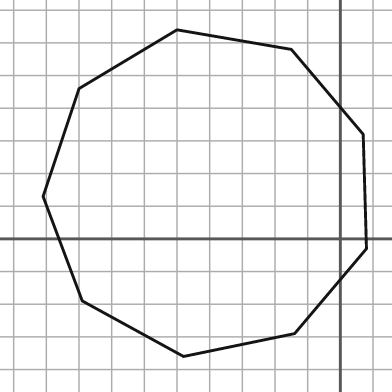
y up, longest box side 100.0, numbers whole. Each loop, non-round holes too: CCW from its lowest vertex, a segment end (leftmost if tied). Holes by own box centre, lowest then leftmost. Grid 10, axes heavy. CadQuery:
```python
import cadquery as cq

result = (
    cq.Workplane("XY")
    .moveTo(-48.0, -36.0)
    .lineTo(-14.0, -29.0)
    .lineTo(8.0, -3.0)
    .lineTo(7.0, 32.0)
    .lineTo(-15.0, 58.0)
    .lineTo(-50.0, 64.0)
    .lineTo(-80.0, 46.0)
    .lineTo(-91.0, 13.0)
    .lineTo(-79.0, -19.0)
    .close()
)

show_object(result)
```